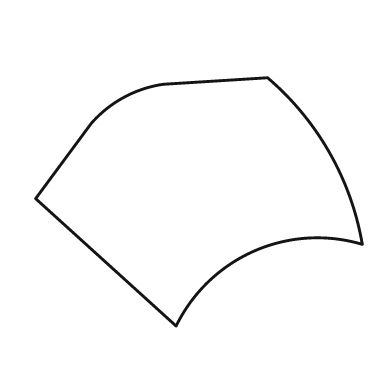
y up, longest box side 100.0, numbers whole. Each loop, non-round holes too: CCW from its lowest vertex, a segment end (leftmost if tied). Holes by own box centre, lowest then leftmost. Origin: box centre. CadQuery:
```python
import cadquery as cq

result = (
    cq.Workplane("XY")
    .moveTo(-7.0, -38.0)
    .threePointArc((17.0, -15.0), (50.0, -13.0))
    .threePointArc((40.0, 15.0), (21.0, 38.0))
    .lineTo(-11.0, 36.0)
    .threePointArc((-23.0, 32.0), (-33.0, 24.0))
    .lineTo(-50.0, 1.0)
    .close()
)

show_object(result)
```